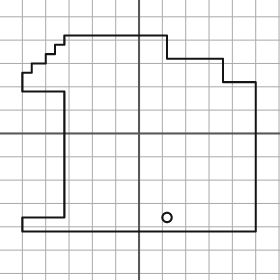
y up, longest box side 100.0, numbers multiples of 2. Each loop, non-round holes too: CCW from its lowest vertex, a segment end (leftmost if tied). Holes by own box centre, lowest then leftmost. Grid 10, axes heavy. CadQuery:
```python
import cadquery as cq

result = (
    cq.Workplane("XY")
    .moveTo(-50.0, -42.0)
    .lineTo(50.0, -42.0)
    .lineTo(50.0, 22.0)
    .lineTo(36.0, 22.0)
    .lineTo(36.0, 32.0)
    .lineTo(12.0, 32.0)
    .lineTo(12.0, 42.0)
    .lineTo(-32.0, 42.0)
    .lineTo(-32.0, 38.0)
    .lineTo(-36.0, 38.0)
    .lineTo(-36.0, 34.0)
    .lineTo(-40.0, 34.0)
    .lineTo(-40.0, 30.0)
    .lineTo(-46.0, 30.0)
    .lineTo(-46.0, 26.0)
    .lineTo(-50.0, 26.0)
    .lineTo(-50.0, 18.0)
    .lineTo(-32.0, 18.0)
    .lineTo(-32.0, -36.0)
    .lineTo(-50.0, -36.0)
    .close()
    .moveTo(12.0, -36.0)
    .circle(2.0)
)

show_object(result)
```